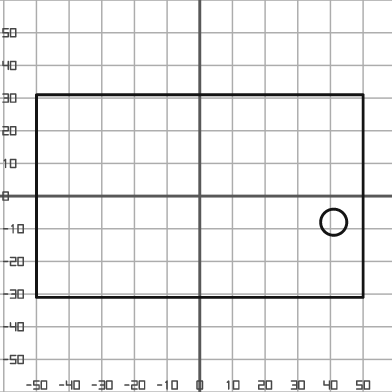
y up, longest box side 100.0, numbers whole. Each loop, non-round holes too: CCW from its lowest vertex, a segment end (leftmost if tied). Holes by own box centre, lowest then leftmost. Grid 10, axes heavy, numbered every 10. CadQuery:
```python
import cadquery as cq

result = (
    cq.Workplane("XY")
    .moveTo(-50.0, -31.0)
    .lineTo(50.0, -31.0)
    .lineTo(50.0, 31.0)
    .lineTo(-50.0, 31.0)
    .close()
    .moveTo(41.0, -8.0)
    .circle(4.0)
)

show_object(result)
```